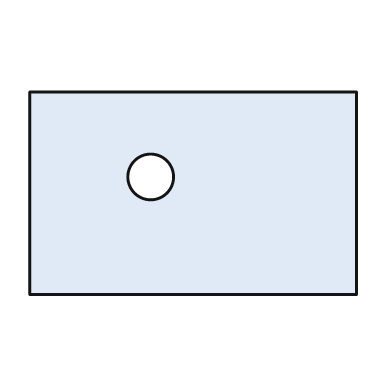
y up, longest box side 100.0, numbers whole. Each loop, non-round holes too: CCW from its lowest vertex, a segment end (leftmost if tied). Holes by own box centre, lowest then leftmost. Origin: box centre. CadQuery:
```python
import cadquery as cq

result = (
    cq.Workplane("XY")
    .moveTo(-50.0, -31.0)
    .lineTo(50.0, -31.0)
    .lineTo(50.0, 31.0)
    .lineTo(-50.0, 31.0)
    .close()
    .moveTo(-13.0, 5.0)
    .circle(7.0)
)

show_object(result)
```